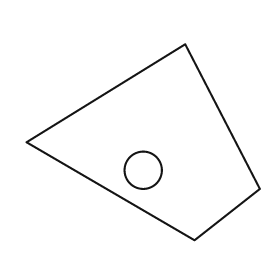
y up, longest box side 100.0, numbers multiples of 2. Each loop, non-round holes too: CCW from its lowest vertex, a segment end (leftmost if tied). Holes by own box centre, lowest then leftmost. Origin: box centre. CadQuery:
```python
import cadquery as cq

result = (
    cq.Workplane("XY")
    .moveTo(22.0, -42.0)
    .lineTo(50.0, -20.0)
    .lineTo(18.0, 42.0)
    .lineTo(-50.0, 0.0)
    .close()
    .moveTo(0.0, -12.0)
    .circle(8.0)
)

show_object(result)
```